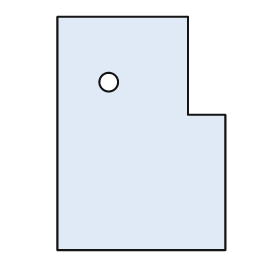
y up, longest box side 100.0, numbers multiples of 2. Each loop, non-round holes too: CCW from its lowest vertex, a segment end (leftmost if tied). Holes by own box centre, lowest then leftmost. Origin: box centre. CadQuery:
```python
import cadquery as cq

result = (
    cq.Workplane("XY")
    .moveTo(-36.0, -50.0)
    .lineTo(36.0, -50.0)
    .lineTo(36.0, 8.0)
    .lineTo(20.0, 8.0)
    .lineTo(20.0, 50.0)
    .lineTo(-36.0, 50.0)
    .close()
    .moveTo(-14.0, 22.0)
    .circle(4.0)
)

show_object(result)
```